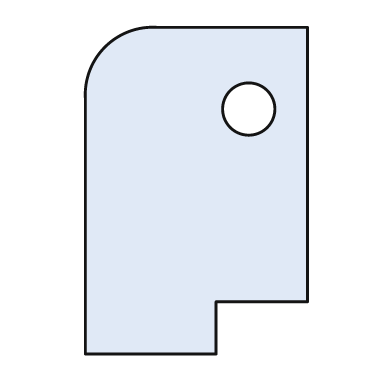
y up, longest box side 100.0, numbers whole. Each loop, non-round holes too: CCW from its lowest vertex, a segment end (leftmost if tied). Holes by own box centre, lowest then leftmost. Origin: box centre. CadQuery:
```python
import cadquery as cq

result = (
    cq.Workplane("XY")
    .moveTo(-34.0, -50.0)
    .lineTo(6.0, -50.0)
    .lineTo(6.0, -34.0)
    .lineTo(34.0, -34.0)
    .lineTo(34.0, 50.0)
    .lineTo(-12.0, 50.0)
    .threePointArc((-28.0, 44.0), (-34.0, 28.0))
    .close()
    .moveTo(16.0, 25.0)
    .circle(8.0)
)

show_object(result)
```